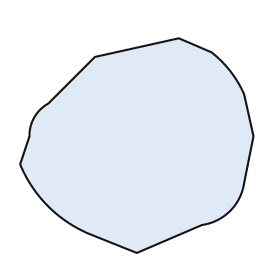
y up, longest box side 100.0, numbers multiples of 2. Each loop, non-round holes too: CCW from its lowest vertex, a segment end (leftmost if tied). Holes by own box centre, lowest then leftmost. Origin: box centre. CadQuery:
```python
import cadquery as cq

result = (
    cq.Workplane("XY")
    .moveTo(0.0, -46.0)
    .lineTo(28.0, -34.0)
    .threePointArc((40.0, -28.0), (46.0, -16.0))
    .lineTo(50.0, 4.0)
    .lineTo(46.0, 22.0)
    .threePointArc((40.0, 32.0), (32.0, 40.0))
    .lineTo(18.0, 46.0)
    .lineTo(-18.0, 38.0)
    .lineTo(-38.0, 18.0)
    .threePointArc((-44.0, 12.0), (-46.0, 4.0))
    .lineTo(-50.0, -8.0)
    .threePointArc((-38.0, -26.0), (-20.0, -38.0))
    .close()
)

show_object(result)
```